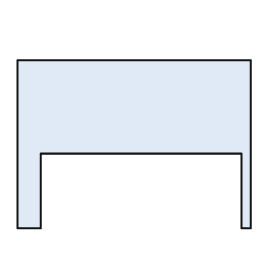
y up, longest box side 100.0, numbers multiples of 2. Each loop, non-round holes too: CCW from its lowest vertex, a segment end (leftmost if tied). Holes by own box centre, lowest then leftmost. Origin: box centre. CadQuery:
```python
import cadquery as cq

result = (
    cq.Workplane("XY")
    .moveTo(-50.0, -36.0)
    .lineTo(-40.0, -36.0)
    .lineTo(-40.0, -4.0)
    .lineTo(46.0, -4.0)
    .lineTo(46.0, -36.0)
    .lineTo(50.0, -36.0)
    .lineTo(50.0, 36.0)
    .lineTo(-50.0, 36.0)
    .close()
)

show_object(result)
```